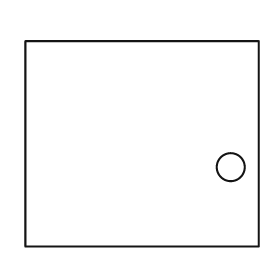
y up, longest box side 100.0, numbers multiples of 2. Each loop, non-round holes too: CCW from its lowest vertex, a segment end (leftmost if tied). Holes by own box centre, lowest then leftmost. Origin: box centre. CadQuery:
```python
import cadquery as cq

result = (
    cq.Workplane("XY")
    .moveTo(-50.0, -44.0)
    .lineTo(50.0, -44.0)
    .lineTo(50.0, 44.0)
    .lineTo(-50.0, 44.0)
    .close()
    .moveTo(38.0, -10.0)
    .circle(6.0)
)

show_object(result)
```